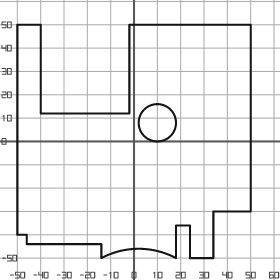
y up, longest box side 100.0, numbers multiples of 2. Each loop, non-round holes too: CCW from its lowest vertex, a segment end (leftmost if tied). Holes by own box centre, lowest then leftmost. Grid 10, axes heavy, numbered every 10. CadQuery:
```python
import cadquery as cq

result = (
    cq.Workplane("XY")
    .moveTo(-14.0, -50.0)
    .threePointArc((2.0, -46.0), (18.0, -50.0))
    .lineTo(18.0, -36.0)
    .lineTo(24.0, -36.0)
    .lineTo(24.0, -50.0)
    .lineTo(34.0, -50.0)
    .lineTo(34.0, -30.0)
    .lineTo(50.0, -30.0)
    .lineTo(50.0, 50.0)
    .lineTo(-2.0, 50.0)
    .lineTo(-2.0, 12.0)
    .lineTo(-40.0, 12.0)
    .lineTo(-40.0, 50.0)
    .lineTo(-50.0, 50.0)
    .lineTo(-50.0, -40.0)
    .lineTo(-46.0, -40.0)
    .lineTo(-46.0, -44.0)
    .lineTo(-14.0, -44.0)
    .close()
    .moveTo(10.0, 8.0)
    .circle(8.0)
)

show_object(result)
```